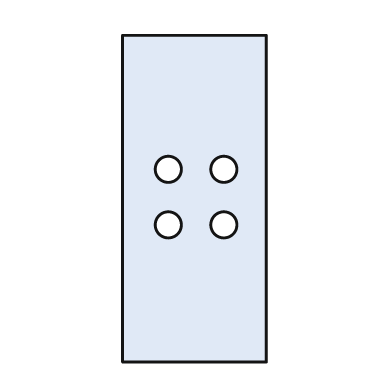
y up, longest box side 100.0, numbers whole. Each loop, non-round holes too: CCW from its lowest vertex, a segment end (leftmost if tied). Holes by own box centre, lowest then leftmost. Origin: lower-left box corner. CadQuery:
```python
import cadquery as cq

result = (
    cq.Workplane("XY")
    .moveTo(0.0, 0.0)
    .lineTo(44.0, 0.0)
    .lineTo(44.0, 100.0)
    .lineTo(0.0, 100.0)
    .close()
    .moveTo(14.0, 42.0)
    .circle(4.0)
    .moveTo(31.0, 42.0)
    .circle(4.0)
    .moveTo(14.0, 59.0)
    .circle(4.0)
    .moveTo(31.0, 59.0)
    .circle(4.0)
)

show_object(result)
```